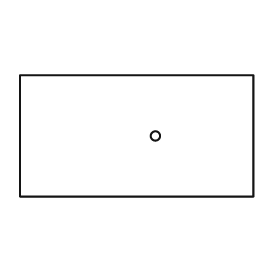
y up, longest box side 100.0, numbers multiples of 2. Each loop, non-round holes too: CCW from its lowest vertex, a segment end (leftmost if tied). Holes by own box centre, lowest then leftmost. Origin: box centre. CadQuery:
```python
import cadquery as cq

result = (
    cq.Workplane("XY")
    .moveTo(-50.0, -26.0)
    .lineTo(50.0, -26.0)
    .lineTo(50.0, 26.0)
    .lineTo(-50.0, 26.0)
    .close()
    .moveTo(8.0, 0.0)
    .circle(2.0)
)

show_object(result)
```